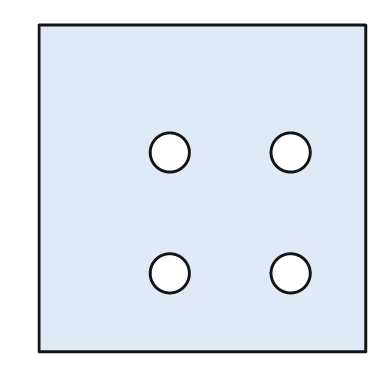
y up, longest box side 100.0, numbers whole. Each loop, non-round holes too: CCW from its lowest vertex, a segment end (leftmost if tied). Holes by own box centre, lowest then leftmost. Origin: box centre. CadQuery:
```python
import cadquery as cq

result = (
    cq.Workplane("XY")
    .moveTo(-50.0, -50.0)
    .lineTo(50.0, -50.0)
    .lineTo(50.0, 50.0)
    .lineTo(-50.0, 50.0)
    .close()
    .moveTo(-10.0, -26.0)
    .circle(6.0)
    .moveTo(27.0, -26.0)
    .circle(6.0)
    .moveTo(-10.0, 11.0)
    .circle(6.0)
    .moveTo(27.0, 11.0)
    .circle(6.0)
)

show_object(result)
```